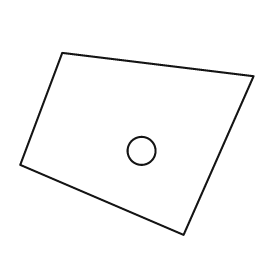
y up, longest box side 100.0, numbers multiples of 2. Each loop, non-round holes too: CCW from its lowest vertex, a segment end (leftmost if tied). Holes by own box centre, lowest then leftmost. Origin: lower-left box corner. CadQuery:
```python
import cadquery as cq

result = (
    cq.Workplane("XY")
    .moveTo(70.0, 0.0)
    .lineTo(100.0, 68.0)
    .lineTo(18.0, 78.0)
    .lineTo(0.0, 30.0)
    .close()
    .moveTo(52.0, 36.0)
    .circle(6.0)
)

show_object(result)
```